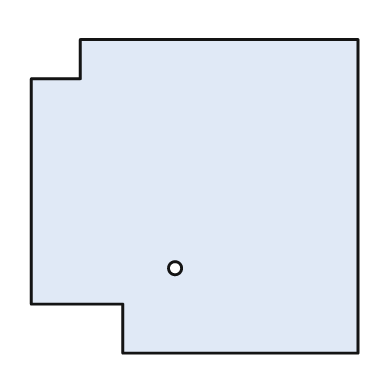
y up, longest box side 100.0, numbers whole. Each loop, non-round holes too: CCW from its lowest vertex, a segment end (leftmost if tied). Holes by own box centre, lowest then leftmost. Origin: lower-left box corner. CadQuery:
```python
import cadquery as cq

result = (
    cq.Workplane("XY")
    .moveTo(28.0, 0.0)
    .lineTo(100.0, 0.0)
    .lineTo(100.0, 96.0)
    .lineTo(15.0, 96.0)
    .lineTo(15.0, 84.0)
    .lineTo(0.0, 84.0)
    .lineTo(0.0, 15.0)
    .lineTo(28.0, 15.0)
    .close()
    .moveTo(44.0, 26.0)
    .circle(2.0)
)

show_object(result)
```